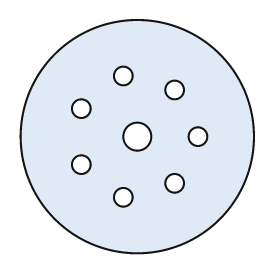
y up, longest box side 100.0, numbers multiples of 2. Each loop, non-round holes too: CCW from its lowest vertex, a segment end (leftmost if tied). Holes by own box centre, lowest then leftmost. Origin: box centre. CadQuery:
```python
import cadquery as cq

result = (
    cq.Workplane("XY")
    .moveTo(0.0, 0.0)
    .circle(50.0)
    .moveTo(-6.0, -26.0)
    .circle(4.0)
    .moveTo(16.0, -20.0)
    .circle(4.0)
    .moveTo(-24.0, -12.0)
    .circle(4.0)
    .moveTo(0.0, 0.0)
    .circle(6.0)
    .moveTo(26.0, 0.0)
    .circle(4.0)
    .moveTo(-24.0, 12.0)
    .circle(4.0)
    .moveTo(16.0, 20.0)
    .circle(4.0)
    .moveTo(-6.0, 26.0)
    .circle(4.0)
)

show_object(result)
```